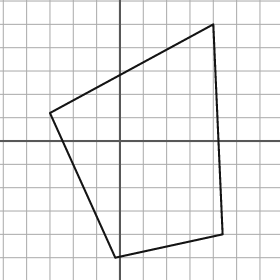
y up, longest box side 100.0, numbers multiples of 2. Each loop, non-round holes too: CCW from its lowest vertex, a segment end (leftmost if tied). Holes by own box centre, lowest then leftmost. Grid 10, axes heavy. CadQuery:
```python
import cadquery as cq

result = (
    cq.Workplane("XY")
    .moveTo(-2.0, -50.0)
    .lineTo(44.0, -40.0)
    .lineTo(40.0, 50.0)
    .lineTo(-30.0, 12.0)
    .close()
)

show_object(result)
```